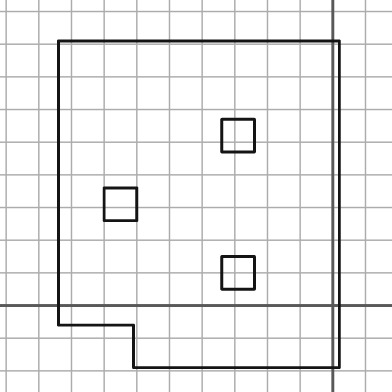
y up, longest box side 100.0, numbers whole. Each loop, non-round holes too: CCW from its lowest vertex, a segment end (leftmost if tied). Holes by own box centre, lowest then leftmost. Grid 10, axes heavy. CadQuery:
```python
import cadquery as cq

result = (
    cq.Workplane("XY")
    .moveTo(-61.0, -19.0)
    .lineTo(2.0, -19.0)
    .lineTo(2.0, 81.0)
    .lineTo(-84.0, 81.0)
    .lineTo(-84.0, -6.0)
    .lineTo(-61.0, -6.0)
    .close()
    .moveTo(-34.0, 5.0)
    .lineTo(-24.0, 5.0)
    .lineTo(-24.0, 15.0)
    .lineTo(-34.0, 15.0)
    .close()
    .moveTo(-70.0, 26.0)
    .lineTo(-60.0, 26.0)
    .lineTo(-60.0, 36.0)
    .lineTo(-70.0, 36.0)
    .close()
    .moveTo(-34.0, 47.0)
    .lineTo(-24.0, 47.0)
    .lineTo(-24.0, 57.0)
    .lineTo(-34.0, 57.0)
    .close()
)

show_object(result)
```